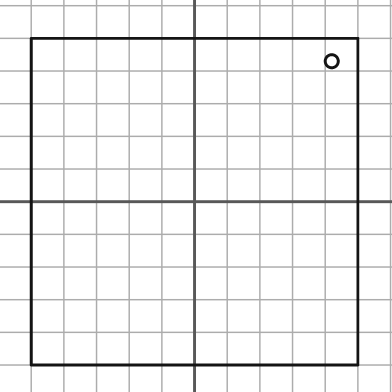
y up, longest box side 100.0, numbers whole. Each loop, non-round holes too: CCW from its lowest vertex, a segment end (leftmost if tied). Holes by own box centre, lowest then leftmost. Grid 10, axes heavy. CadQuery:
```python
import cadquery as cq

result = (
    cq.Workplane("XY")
    .moveTo(-50.0, -50.0)
    .lineTo(50.0, -50.0)
    .lineTo(50.0, 50.0)
    .lineTo(-50.0, 50.0)
    .close()
    .moveTo(42.0, 43.0)
    .circle(2.0)
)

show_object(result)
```